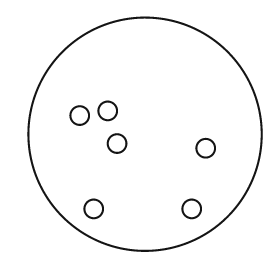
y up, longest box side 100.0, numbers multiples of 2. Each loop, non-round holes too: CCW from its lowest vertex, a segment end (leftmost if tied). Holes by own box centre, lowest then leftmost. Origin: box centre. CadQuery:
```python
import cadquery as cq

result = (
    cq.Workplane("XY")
    .moveTo(0.0, 0.0)
    .circle(50.0)
    .moveTo(-22.0, -32.0)
    .circle(4.0)
    .moveTo(20.0, -32.0)
    .circle(4.0)
    .moveTo(26.0, -6.0)
    .circle(4.0)
    .moveTo(-12.0, -4.0)
    .circle(4.0)
    .moveTo(-28.0, 8.0)
    .circle(4.0)
    .moveTo(-16.0, 10.0)
    .circle(4.0)
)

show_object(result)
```